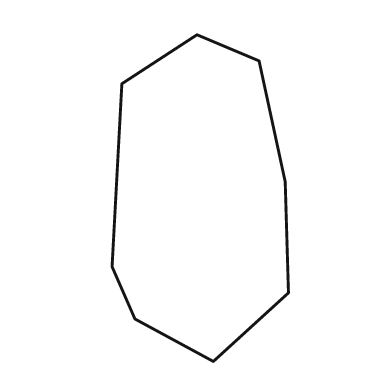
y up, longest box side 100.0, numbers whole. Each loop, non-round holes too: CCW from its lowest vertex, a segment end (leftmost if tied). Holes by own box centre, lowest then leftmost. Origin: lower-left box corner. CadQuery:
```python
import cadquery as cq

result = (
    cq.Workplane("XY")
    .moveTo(31.0, 0.0)
    .lineTo(54.0, 21.0)
    .lineTo(53.0, 55.0)
    .lineTo(45.0, 92.0)
    .lineTo(26.0, 100.0)
    .lineTo(3.0, 85.0)
    .lineTo(0.0, 29.0)
    .lineTo(7.0, 13.0)
    .close()
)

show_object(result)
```